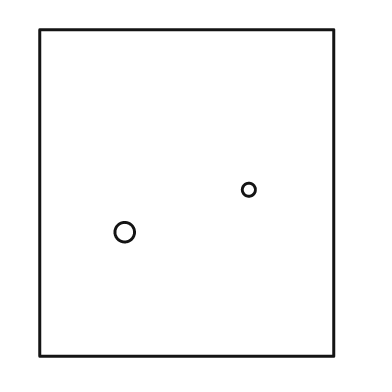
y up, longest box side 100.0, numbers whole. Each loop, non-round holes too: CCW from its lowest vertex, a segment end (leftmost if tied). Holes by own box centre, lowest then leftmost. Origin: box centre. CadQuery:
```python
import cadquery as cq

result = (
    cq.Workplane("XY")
    .moveTo(-45.0, -50.0)
    .lineTo(45.0, -50.0)
    .lineTo(45.0, 50.0)
    .lineTo(-45.0, 50.0)
    .close()
    .moveTo(-19.0, -12.0)
    .circle(3.0)
    .moveTo(19.0, 1.0)
    .circle(2.0)
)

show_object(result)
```